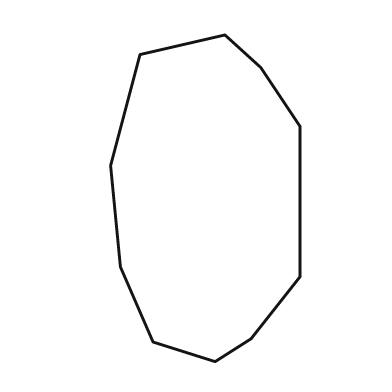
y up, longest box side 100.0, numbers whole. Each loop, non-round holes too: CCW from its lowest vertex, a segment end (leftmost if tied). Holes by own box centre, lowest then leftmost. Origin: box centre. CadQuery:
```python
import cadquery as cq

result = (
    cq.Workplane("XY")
    .moveTo(3.0, -50.0)
    .lineTo(14.0, -43.0)
    .lineTo(29.0, -24.0)
    .lineTo(29.0, 22.0)
    .lineTo(17.0, 40.0)
    .lineTo(6.0, 50.0)
    .lineTo(-20.0, 44.0)
    .lineTo(-29.0, 10.0)
    .lineTo(-26.0, -21.0)
    .lineTo(-16.0, -44.0)
    .close()
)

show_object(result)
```